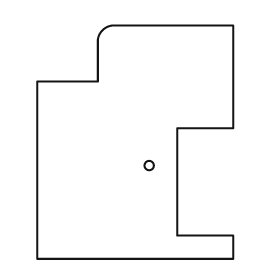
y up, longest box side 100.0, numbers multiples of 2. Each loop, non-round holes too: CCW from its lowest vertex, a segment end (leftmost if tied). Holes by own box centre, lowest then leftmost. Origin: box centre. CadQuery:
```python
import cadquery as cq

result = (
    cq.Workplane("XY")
    .moveTo(-42.0, -50.0)
    .lineTo(42.0, -50.0)
    .lineTo(42.0, -40.0)
    .lineTo(18.0, -40.0)
    .lineTo(18.0, 6.0)
    .lineTo(42.0, 6.0)
    .lineTo(42.0, 50.0)
    .lineTo(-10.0, 50.0)
    .threePointArc((-14.0, 48.0), (-16.0, 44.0))
    .lineTo(-16.0, 26.0)
    .lineTo(-42.0, 26.0)
    .close()
    .moveTo(6.0, -10.0)
    .circle(2.0)
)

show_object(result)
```